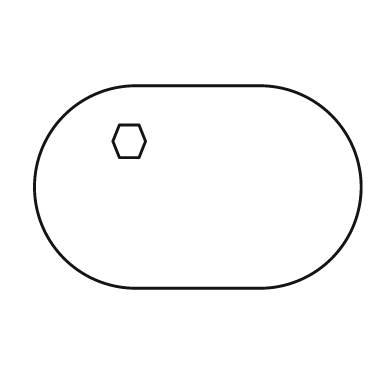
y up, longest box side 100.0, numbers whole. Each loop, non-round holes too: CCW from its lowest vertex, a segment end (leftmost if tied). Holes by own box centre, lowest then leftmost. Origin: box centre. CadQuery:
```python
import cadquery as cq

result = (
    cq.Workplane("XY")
    .moveTo(-19.0, -31.0)
    .lineTo(19.0, -31.0)
    .threePointArc((50.0, 0.0), (19.0, 31.0))
    .lineTo(-19.0, 31.0)
    .threePointArc((-50.0, 0.0), (-19.0, -31.0))
    .close()
    .moveTo(-24.0, 9.0)
    .lineTo(-18.0, 9.0)
    .lineTo(-16.0, 14.0)
    .lineTo(-18.0, 19.0)
    .lineTo(-24.0, 19.0)
    .lineTo(-26.0, 14.0)
    .close()
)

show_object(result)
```